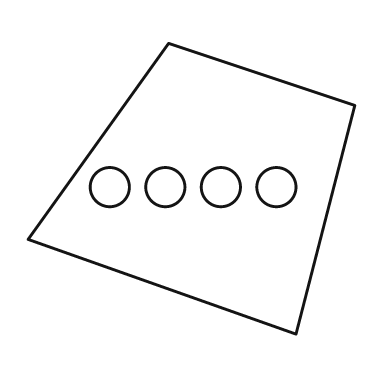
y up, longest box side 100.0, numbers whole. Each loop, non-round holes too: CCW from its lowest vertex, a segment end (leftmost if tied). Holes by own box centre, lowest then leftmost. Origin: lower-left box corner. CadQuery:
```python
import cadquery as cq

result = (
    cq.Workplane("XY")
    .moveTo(82.0, 0.0)
    .lineTo(100.0, 70.0)
    .lineTo(43.0, 89.0)
    .lineTo(0.0, 29.0)
    .close()
    .moveTo(25.0, 45.0)
    .circle(6.0)
    .moveTo(42.0, 45.0)
    .circle(6.0)
    .moveTo(59.0, 45.0)
    .circle(6.0)
    .moveTo(76.0, 45.0)
    .circle(6.0)
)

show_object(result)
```